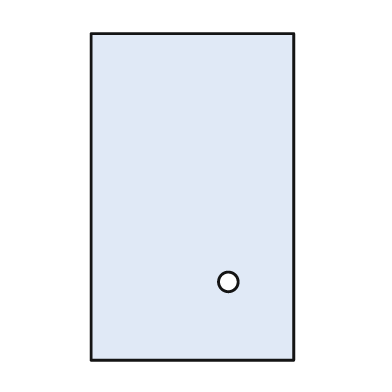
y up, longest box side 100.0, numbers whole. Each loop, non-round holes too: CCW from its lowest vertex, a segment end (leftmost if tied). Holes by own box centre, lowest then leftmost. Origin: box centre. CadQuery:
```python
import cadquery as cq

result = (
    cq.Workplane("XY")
    .moveTo(-31.0, -50.0)
    .lineTo(31.0, -50.0)
    .lineTo(31.0, 50.0)
    .lineTo(-31.0, 50.0)
    .close()
    .moveTo(11.0, -26.0)
    .circle(3.0)
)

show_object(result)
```